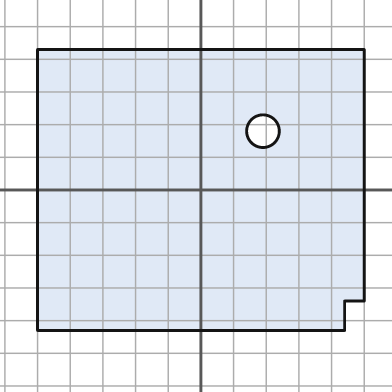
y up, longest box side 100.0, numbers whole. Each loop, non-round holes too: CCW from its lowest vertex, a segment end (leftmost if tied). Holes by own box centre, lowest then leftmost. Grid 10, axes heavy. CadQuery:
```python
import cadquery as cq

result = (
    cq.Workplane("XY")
    .moveTo(-50.0, -43.0)
    .lineTo(44.0, -43.0)
    .lineTo(44.0, -34.0)
    .lineTo(50.0, -34.0)
    .lineTo(50.0, 43.0)
    .lineTo(-50.0, 43.0)
    .close()
    .moveTo(19.0, 18.0)
    .circle(5.0)
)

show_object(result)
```